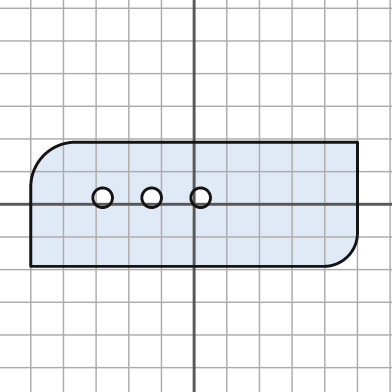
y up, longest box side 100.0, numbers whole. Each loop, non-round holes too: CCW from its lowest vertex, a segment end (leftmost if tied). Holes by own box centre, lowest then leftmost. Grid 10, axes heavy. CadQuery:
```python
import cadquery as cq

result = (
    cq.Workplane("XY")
    .moveTo(-50.0, -19.0)
    .lineTo(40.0, -19.0)
    .threePointArc((47.0, -16.0), (50.0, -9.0))
    .lineTo(50.0, 19.0)
    .lineTo(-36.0, 19.0)
    .threePointArc((-46.0, 15.0), (-50.0, 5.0))
    .close()
    .moveTo(-28.0, 2.0)
    .circle(3.0)
    .moveTo(-13.0, 2.0)
    .circle(3.0)
    .moveTo(2.0, 2.0)
    .circle(3.0)
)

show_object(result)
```